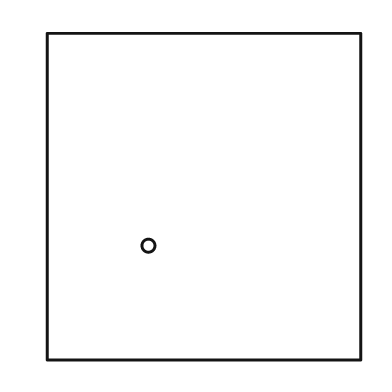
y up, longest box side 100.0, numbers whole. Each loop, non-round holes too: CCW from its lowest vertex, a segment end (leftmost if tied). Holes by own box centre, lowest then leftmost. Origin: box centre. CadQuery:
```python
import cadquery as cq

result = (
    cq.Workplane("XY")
    .moveTo(-48.0, -50.0)
    .lineTo(48.0, -50.0)
    .lineTo(48.0, 50.0)
    .lineTo(-48.0, 50.0)
    .close()
    .moveTo(-17.0, -15.0)
    .circle(2.0)
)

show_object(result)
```